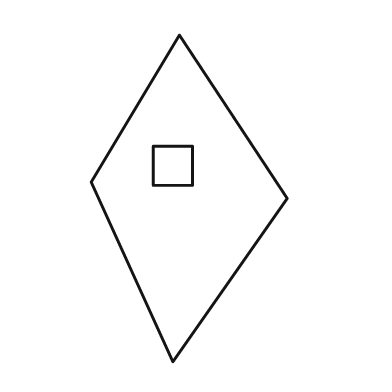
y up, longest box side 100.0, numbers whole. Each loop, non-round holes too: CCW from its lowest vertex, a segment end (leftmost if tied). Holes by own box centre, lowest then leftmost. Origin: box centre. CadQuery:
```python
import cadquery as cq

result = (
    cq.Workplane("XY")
    .moveTo(-5.0, -50.0)
    .lineTo(30.0, 0.0)
    .lineTo(-3.0, 50.0)
    .lineTo(-30.0, 5.0)
    .close()
    .moveTo(-11.0, 4.0)
    .lineTo(1.0, 4.0)
    .lineTo(1.0, 16.0)
    .lineTo(-11.0, 16.0)
    .close()
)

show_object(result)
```